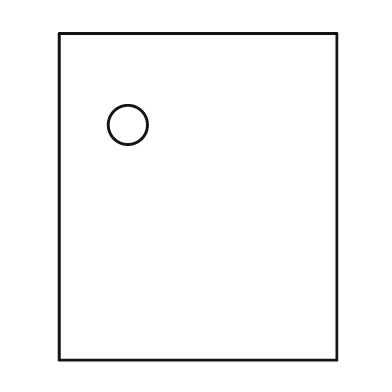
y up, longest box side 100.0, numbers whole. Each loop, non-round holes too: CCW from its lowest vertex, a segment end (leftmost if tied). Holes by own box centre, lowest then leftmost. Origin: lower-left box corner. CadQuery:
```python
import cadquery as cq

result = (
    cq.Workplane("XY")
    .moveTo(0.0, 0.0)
    .lineTo(85.0, 0.0)
    .lineTo(85.0, 100.0)
    .lineTo(0.0, 100.0)
    .close()
    .moveTo(21.0, 72.0)
    .circle(6.0)
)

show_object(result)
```